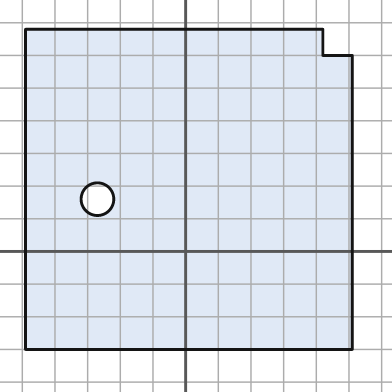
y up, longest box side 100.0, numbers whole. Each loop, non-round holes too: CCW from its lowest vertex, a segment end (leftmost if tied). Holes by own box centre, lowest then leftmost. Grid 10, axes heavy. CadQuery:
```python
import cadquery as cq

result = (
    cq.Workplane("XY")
    .moveTo(-49.0, -30.0)
    .lineTo(51.0, -30.0)
    .lineTo(51.0, 60.0)
    .lineTo(42.0, 60.0)
    .lineTo(42.0, 68.0)
    .lineTo(-49.0, 68.0)
    .close()
    .moveTo(-27.0, 16.0)
    .circle(5.0)
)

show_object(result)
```